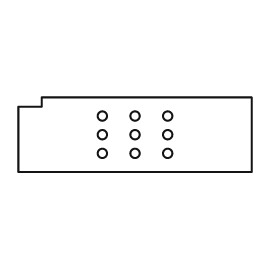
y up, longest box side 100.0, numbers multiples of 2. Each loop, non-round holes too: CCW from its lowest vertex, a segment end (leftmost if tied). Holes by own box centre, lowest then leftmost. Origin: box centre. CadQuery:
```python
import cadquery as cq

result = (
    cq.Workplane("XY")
    .moveTo(-50.0, -16.0)
    .lineTo(50.0, -16.0)
    .lineTo(50.0, 16.0)
    .lineTo(-40.0, 16.0)
    .lineTo(-40.0, 12.0)
    .lineTo(-50.0, 12.0)
    .close()
    .moveTo(-14.0, -8.0)
    .circle(2.0)
    .moveTo(0.0, -8.0)
    .circle(2.0)
    .moveTo(14.0, -8.0)
    .circle(2.0)
    .moveTo(-14.0, 0.0)
    .circle(2.0)
    .moveTo(0.0, 0.0)
    .circle(2.0)
    .moveTo(14.0, 0.0)
    .circle(2.0)
    .moveTo(-14.0, 8.0)
    .circle(2.0)
    .moveTo(0.0, 8.0)
    .circle(2.0)
    .moveTo(14.0, 8.0)
    .circle(2.0)
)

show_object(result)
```